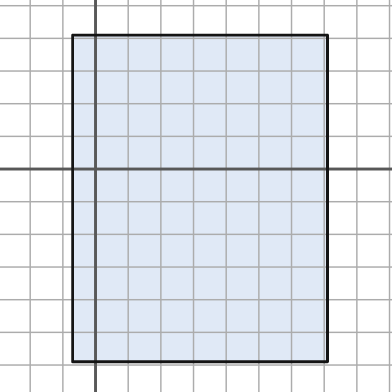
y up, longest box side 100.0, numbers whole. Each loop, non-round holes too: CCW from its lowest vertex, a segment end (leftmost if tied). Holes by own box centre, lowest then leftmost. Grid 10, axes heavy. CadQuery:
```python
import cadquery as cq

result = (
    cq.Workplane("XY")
    .moveTo(-7.0, -59.0)
    .lineTo(71.0, -59.0)
    .lineTo(71.0, 41.0)
    .lineTo(-7.0, 41.0)
    .close()
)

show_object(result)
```